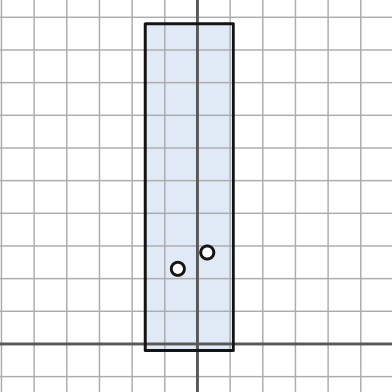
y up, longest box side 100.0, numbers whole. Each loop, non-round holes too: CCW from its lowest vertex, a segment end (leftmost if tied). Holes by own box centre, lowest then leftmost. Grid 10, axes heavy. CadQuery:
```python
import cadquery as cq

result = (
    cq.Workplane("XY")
    .moveTo(-16.0, -2.0)
    .lineTo(11.0, -2.0)
    .lineTo(11.0, 98.0)
    .lineTo(-16.0, 98.0)
    .close()
    .moveTo(-6.0, 23.0)
    .circle(2.0)
    .moveTo(3.0, 28.0)
    .circle(2.0)
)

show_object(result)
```